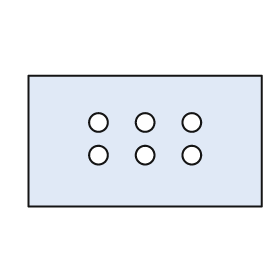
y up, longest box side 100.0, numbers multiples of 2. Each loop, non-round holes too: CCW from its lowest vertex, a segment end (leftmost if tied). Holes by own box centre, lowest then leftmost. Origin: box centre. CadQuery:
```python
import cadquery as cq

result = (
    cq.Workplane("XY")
    .moveTo(-50.0, -28.0)
    .lineTo(50.0, -28.0)
    .lineTo(50.0, 28.0)
    .lineTo(-50.0, 28.0)
    .close()
    .moveTo(-20.0, -6.0)
    .circle(4.0)
    .moveTo(0.0, -6.0)
    .circle(4.0)
    .moveTo(20.0, -6.0)
    .circle(4.0)
    .moveTo(-20.0, 8.0)
    .circle(4.0)
    .moveTo(0.0, 8.0)
    .circle(4.0)
    .moveTo(20.0, 8.0)
    .circle(4.0)
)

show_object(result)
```